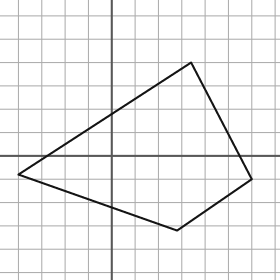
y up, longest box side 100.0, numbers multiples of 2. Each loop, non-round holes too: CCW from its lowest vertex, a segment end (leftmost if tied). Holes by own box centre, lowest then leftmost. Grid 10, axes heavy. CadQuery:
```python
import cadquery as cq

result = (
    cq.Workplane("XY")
    .moveTo(28.0, -32.0)
    .lineTo(60.0, -10.0)
    .lineTo(34.0, 40.0)
    .lineTo(-40.0, -8.0)
    .close()
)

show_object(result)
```